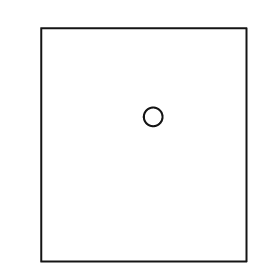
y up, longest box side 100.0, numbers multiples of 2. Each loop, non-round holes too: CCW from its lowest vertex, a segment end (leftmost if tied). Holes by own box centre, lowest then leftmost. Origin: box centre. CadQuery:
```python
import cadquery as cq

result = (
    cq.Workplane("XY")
    .moveTo(-44.0, -50.0)
    .lineTo(44.0, -50.0)
    .lineTo(44.0, 50.0)
    .lineTo(-44.0, 50.0)
    .close()
    .moveTo(4.0, 12.0)
    .circle(4.0)
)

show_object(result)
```